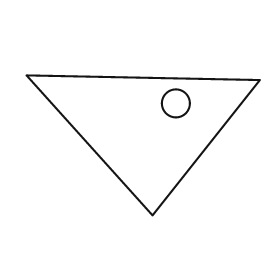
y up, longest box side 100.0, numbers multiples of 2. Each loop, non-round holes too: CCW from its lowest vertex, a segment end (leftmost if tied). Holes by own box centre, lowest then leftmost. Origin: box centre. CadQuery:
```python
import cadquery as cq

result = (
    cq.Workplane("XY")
    .moveTo(4.0, -30.0)
    .lineTo(50.0, 28.0)
    .lineTo(-50.0, 30.0)
    .close()
    .moveTo(14.0, 18.0)
    .circle(6.0)
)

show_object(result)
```